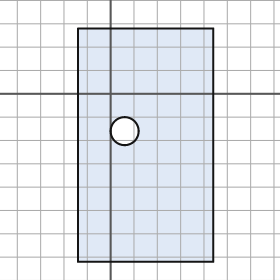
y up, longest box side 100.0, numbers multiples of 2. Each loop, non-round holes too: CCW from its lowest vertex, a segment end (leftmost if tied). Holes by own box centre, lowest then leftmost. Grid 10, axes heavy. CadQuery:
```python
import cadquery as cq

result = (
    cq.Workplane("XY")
    .moveTo(-14.0, -72.0)
    .lineTo(44.0, -72.0)
    .lineTo(44.0, 28.0)
    .lineTo(-14.0, 28.0)
    .close()
    .moveTo(6.0, -16.0)
    .circle(6.0)
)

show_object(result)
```